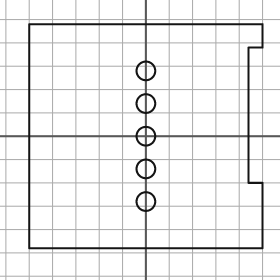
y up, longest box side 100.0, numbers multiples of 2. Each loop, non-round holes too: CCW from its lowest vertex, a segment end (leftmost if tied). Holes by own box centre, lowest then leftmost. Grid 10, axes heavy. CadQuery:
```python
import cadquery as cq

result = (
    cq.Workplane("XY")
    .moveTo(-50.0, -48.0)
    .lineTo(50.0, -48.0)
    .lineTo(50.0, -20.0)
    .lineTo(44.0, -20.0)
    .lineTo(44.0, 38.0)
    .lineTo(50.0, 38.0)
    .lineTo(50.0, 48.0)
    .lineTo(-50.0, 48.0)
    .close()
    .moveTo(0.0, -28.0)
    .circle(4.0)
    .moveTo(0.0, -14.0)
    .circle(4.0)
    .moveTo(0.0, 0.0)
    .circle(4.0)
    .moveTo(0.0, 14.0)
    .circle(4.0)
    .moveTo(0.0, 28.0)
    .circle(4.0)
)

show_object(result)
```